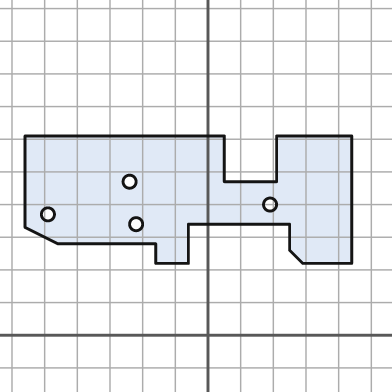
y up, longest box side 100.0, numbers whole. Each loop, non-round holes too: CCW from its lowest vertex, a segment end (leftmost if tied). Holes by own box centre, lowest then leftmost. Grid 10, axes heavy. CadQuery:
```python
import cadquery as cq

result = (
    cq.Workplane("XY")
    .moveTo(-16.0, 22.0)
    .lineTo(-6.0, 22.0)
    .lineTo(-6.0, 34.0)
    .lineTo(25.0, 34.0)
    .lineTo(25.0, 26.0)
    .lineTo(29.0, 22.0)
    .lineTo(44.0, 22.0)
    .lineTo(44.0, 61.0)
    .lineTo(21.0, 61.0)
    .lineTo(21.0, 47.0)
    .lineTo(5.0, 47.0)
    .lineTo(5.0, 61.0)
    .lineTo(-56.0, 61.0)
    .lineTo(-56.0, 33.0)
    .lineTo(-46.0, 28.0)
    .lineTo(-16.0, 28.0)
    .close()
    .moveTo(-22.0, 34.0)
    .circle(2.0)
    .moveTo(-49.0, 37.0)
    .circle(2.0)
    .moveTo(19.0, 40.0)
    .circle(2.0)
    .moveTo(-24.0, 47.0)
    .circle(2.0)
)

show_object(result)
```